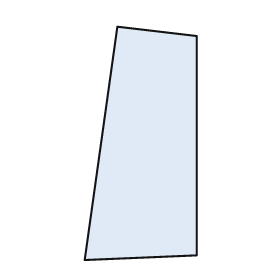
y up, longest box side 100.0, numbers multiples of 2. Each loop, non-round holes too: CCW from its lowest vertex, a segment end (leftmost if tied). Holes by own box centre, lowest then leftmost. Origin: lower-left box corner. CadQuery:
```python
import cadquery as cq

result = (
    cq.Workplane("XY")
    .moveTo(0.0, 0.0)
    .lineTo(48.0, 2.0)
    .lineTo(48.0, 96.0)
    .lineTo(14.0, 100.0)
    .close()
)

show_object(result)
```